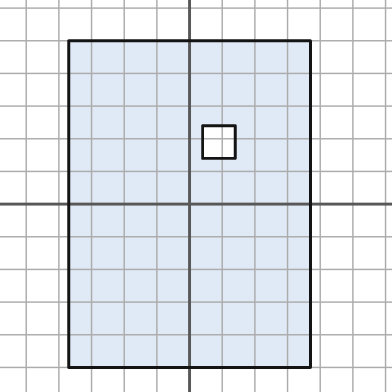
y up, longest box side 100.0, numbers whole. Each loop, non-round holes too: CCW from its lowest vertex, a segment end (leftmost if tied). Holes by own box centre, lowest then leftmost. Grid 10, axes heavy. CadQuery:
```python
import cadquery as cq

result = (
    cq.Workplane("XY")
    .moveTo(-37.0, -50.0)
    .lineTo(37.0, -50.0)
    .lineTo(37.0, 50.0)
    .lineTo(-37.0, 50.0)
    .close()
    .moveTo(4.0, 14.0)
    .lineTo(14.0, 14.0)
    .lineTo(14.0, 24.0)
    .lineTo(4.0, 24.0)
    .close()
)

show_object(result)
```